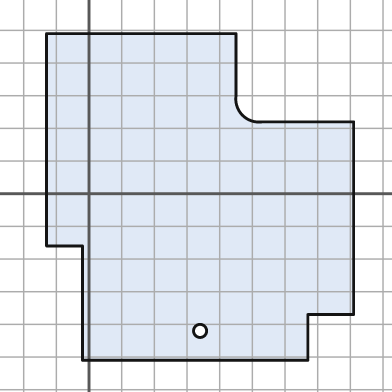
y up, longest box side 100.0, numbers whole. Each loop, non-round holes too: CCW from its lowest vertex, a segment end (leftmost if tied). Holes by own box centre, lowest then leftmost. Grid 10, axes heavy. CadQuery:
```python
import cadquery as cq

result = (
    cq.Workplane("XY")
    .moveTo(-2.0, -51.0)
    .lineTo(67.0, -51.0)
    .lineTo(67.0, -37.0)
    .lineTo(81.0, -37.0)
    .lineTo(81.0, 22.0)
    .lineTo(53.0, 22.0)
    .threePointArc((47.0, 24.0), (45.0, 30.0))
    .lineTo(45.0, 49.0)
    .lineTo(-13.0, 49.0)
    .lineTo(-13.0, -16.0)
    .lineTo(-2.0, -16.0)
    .close()
    .moveTo(34.0, -42.0)
    .circle(2.0)
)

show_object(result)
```